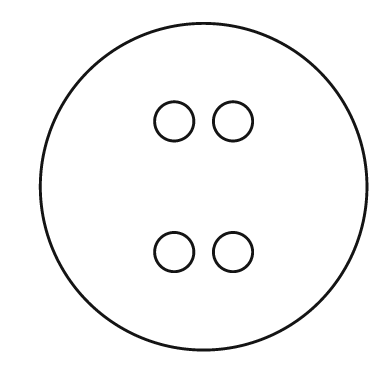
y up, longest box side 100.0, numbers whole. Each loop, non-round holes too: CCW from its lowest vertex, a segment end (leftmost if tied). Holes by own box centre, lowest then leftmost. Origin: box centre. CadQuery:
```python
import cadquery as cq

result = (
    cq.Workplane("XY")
    .moveTo(0.0, 0.0)
    .circle(50.0)
    .moveTo(-9.0, -20.0)
    .circle(6.0)
    .moveTo(9.0, -20.0)
    .circle(6.0)
    .moveTo(-9.0, 20.0)
    .circle(6.0)
    .moveTo(9.0, 20.0)
    .circle(6.0)
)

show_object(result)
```